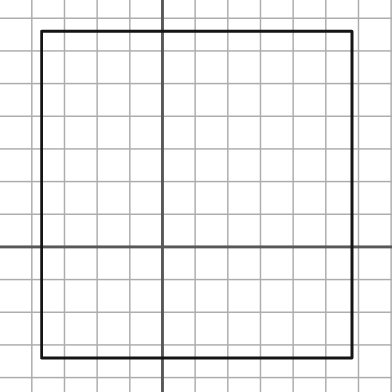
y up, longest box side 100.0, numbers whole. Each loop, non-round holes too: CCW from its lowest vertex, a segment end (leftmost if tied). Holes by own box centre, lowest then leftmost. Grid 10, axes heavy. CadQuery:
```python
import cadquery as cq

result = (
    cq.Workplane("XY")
    .moveTo(-37.0, -34.0)
    .lineTo(58.0, -34.0)
    .lineTo(58.0, 66.0)
    .lineTo(-37.0, 66.0)
    .close()
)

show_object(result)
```